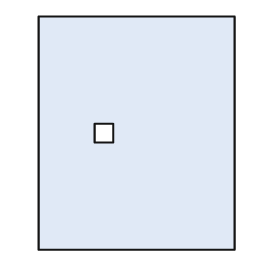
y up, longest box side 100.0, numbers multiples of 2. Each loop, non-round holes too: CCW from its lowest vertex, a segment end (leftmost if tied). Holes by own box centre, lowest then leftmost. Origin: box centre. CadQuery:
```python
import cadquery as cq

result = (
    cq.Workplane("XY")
    .moveTo(-42.0, -50.0)
    .lineTo(42.0, -50.0)
    .lineTo(42.0, 50.0)
    .lineTo(-42.0, 50.0)
    .close()
    .moveTo(-18.0, -4.0)
    .lineTo(-10.0, -4.0)
    .lineTo(-10.0, 4.0)
    .lineTo(-18.0, 4.0)
    .close()
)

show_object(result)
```